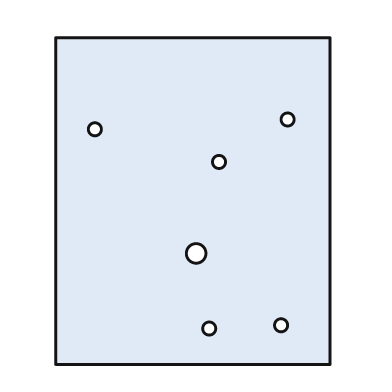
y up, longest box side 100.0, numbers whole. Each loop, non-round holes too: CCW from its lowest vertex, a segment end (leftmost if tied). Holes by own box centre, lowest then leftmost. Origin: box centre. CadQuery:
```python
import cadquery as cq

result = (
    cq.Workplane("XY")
    .moveTo(-42.0, -50.0)
    .lineTo(42.0, -50.0)
    .lineTo(42.0, 50.0)
    .lineTo(-42.0, 50.0)
    .close()
    .moveTo(5.0, -39.0)
    .circle(2.0)
    .moveTo(27.0, -38.0)
    .circle(2.0)
    .moveTo(1.0, -16.0)
    .circle(3.0)
    .moveTo(8.0, 12.0)
    .circle(2.0)
    .moveTo(-30.0, 22.0)
    .circle(2.0)
    .moveTo(29.0, 25.0)
    .circle(2.0)
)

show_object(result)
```